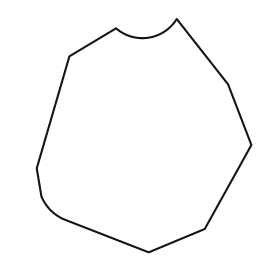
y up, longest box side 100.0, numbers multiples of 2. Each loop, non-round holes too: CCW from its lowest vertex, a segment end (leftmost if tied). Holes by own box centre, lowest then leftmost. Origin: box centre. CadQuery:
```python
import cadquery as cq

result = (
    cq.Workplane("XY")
    .moveTo(2.0, -50.0)
    .lineTo(26.0, -40.0)
    .lineTo(46.0, -4.0)
    .lineTo(36.0, 22.0)
    .lineTo(14.0, 50.0)
    .threePointArc((2.0, 42.0), (-12.0, 46.0))
    .lineTo(-32.0, 34.0)
    .lineTo(-46.0, -14.0)
    .lineTo(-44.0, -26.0)
    .threePointArc((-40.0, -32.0), (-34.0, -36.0))
    .close()
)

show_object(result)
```